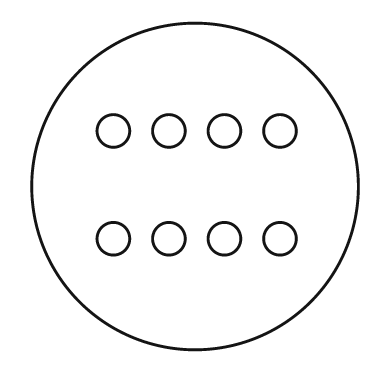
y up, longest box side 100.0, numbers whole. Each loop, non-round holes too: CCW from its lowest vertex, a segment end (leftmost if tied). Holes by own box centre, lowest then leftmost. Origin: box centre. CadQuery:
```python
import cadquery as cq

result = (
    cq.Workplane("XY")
    .moveTo(0.0, 0.0)
    .circle(50.0)
    .moveTo(-25.0, -16.0)
    .circle(5.0)
    .moveTo(-8.0, -16.0)
    .circle(5.0)
    .moveTo(9.0, -16.0)
    .circle(5.0)
    .moveTo(26.0, -16.0)
    .circle(5.0)
    .moveTo(-25.0, 17.0)
    .circle(5.0)
    .moveTo(-8.0, 17.0)
    .circle(5.0)
    .moveTo(9.0, 17.0)
    .circle(5.0)
    .moveTo(26.0, 17.0)
    .circle(5.0)
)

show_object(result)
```